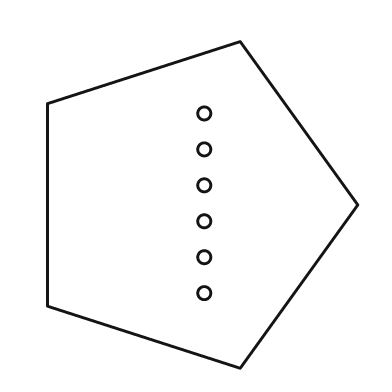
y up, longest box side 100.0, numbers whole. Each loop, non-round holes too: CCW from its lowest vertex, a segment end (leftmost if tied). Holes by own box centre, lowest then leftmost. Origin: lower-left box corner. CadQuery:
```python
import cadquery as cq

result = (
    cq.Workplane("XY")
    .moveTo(59.0, 0.0)
    .lineTo(95.0, 50.0)
    .lineTo(59.0, 100.0)
    .lineTo(0.0, 81.0)
    .lineTo(0.0, 19.0)
    .close()
    .moveTo(48.0, 23.0)
    .circle(2.0)
    .moveTo(48.0, 34.0)
    .circle(2.0)
    .moveTo(48.0, 45.0)
    .circle(2.0)
    .moveTo(48.0, 56.0)
    .circle(2.0)
    .moveTo(48.0, 67.0)
    .circle(2.0)
    .moveTo(48.0, 78.0)
    .circle(2.0)
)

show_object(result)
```